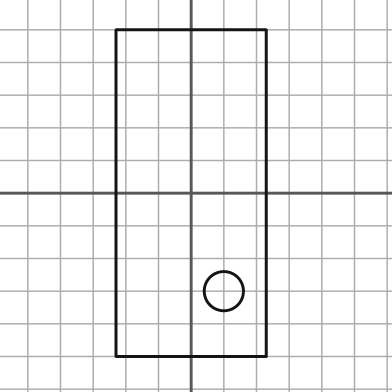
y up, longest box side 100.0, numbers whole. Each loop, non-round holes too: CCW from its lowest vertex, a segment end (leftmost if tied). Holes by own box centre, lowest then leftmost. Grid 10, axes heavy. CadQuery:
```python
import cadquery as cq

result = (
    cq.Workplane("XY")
    .moveTo(-23.0, -50.0)
    .lineTo(23.0, -50.0)
    .lineTo(23.0, 50.0)
    .lineTo(-23.0, 50.0)
    .close()
    .moveTo(10.0, -30.0)
    .circle(6.0)
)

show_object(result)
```